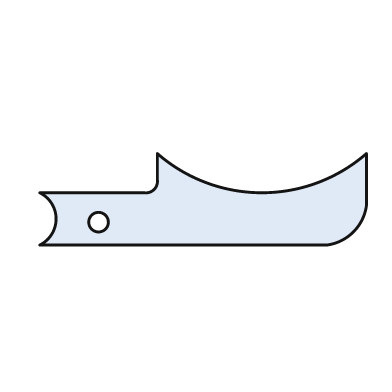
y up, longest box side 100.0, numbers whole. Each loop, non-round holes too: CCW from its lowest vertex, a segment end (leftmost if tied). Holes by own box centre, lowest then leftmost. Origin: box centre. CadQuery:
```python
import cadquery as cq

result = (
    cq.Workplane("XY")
    .moveTo(-50.0, -14.0)
    .lineTo(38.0, -14.0)
    .threePointArc((46.0, -10.0), (50.0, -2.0))
    .lineTo(50.0, 14.0)
    .threePointArc((18.0, 2.0), (-14.0, 14.0))
    .lineTo(-14.0, 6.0)
    .threePointArc((-15.0, 3.0), (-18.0, 2.0))
    .lineTo(-50.0, 2.0)
    .threePointArc((-45.0, -6.0), (-50.0, -14.0))
    .close()
    .moveTo(-32.0, -7.0)
    .circle(3.0)
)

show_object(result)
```